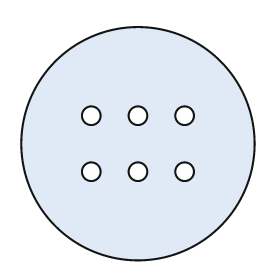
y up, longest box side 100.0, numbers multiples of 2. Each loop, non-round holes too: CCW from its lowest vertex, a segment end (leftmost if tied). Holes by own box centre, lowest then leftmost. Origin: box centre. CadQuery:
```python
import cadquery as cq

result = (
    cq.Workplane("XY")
    .moveTo(0.0, 0.0)
    .circle(50.0)
    .moveTo(-20.0, -12.0)
    .circle(4.0)
    .moveTo(0.0, -12.0)
    .circle(4.0)
    .moveTo(20.0, -12.0)
    .circle(4.0)
    .moveTo(-20.0, 12.0)
    .circle(4.0)
    .moveTo(0.0, 12.0)
    .circle(4.0)
    .moveTo(20.0, 12.0)
    .circle(4.0)
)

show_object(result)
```